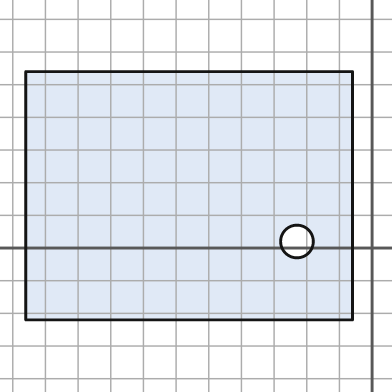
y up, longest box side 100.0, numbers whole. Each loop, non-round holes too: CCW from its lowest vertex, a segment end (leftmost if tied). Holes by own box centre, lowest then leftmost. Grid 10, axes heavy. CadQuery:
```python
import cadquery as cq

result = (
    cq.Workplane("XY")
    .moveTo(-106.0, -22.0)
    .lineTo(-6.0, -22.0)
    .lineTo(-6.0, 54.0)
    .lineTo(-106.0, 54.0)
    .close()
    .moveTo(-23.0, 2.0)
    .circle(5.0)
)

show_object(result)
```